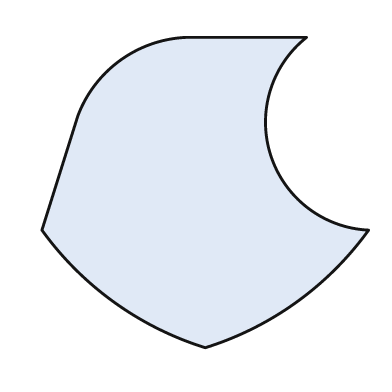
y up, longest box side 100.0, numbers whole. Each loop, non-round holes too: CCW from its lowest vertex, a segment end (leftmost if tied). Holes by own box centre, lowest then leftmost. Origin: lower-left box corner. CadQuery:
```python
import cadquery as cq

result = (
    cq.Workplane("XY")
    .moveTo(50.0, 0.0)
    .threePointArc((78.0, 14.0), (100.0, 36.0))
    .threePointArc((70.0, 59.0), (81.0, 95.0))
    .lineTo(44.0, 95.0)
    .threePointArc((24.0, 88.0), (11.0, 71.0))
    .lineTo(0.0, 36.0)
    .threePointArc((22.0, 14.0), (50.0, 0.0))
    .close()
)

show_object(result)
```